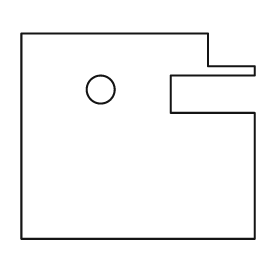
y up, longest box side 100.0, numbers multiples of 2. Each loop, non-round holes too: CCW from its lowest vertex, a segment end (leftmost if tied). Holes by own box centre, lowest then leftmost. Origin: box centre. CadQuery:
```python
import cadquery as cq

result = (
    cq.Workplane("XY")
    .moveTo(-50.0, -44.0)
    .lineTo(50.0, -44.0)
    .lineTo(50.0, 10.0)
    .lineTo(14.0, 10.0)
    .lineTo(14.0, 26.0)
    .lineTo(50.0, 26.0)
    .lineTo(50.0, 30.0)
    .lineTo(30.0, 30.0)
    .lineTo(30.0, 44.0)
    .lineTo(-50.0, 44.0)
    .close()
    .moveTo(-16.0, 20.0)
    .circle(6.0)
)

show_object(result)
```